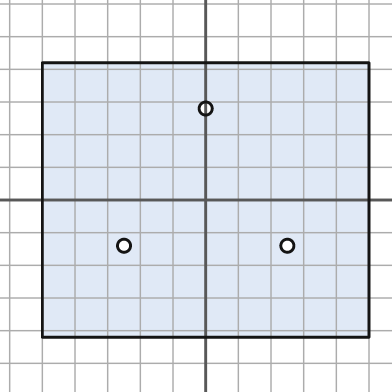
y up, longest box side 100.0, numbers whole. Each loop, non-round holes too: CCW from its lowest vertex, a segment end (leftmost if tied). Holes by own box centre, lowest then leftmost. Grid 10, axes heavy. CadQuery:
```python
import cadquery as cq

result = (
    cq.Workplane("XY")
    .moveTo(-50.0, -42.0)
    .lineTo(50.0, -42.0)
    .lineTo(50.0, 42.0)
    .lineTo(-50.0, 42.0)
    .close()
    .moveTo(-25.0, -14.0)
    .circle(2.0)
    .moveTo(25.0, -14.0)
    .circle(2.0)
    .moveTo(0.0, 28.0)
    .circle(2.0)
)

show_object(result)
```